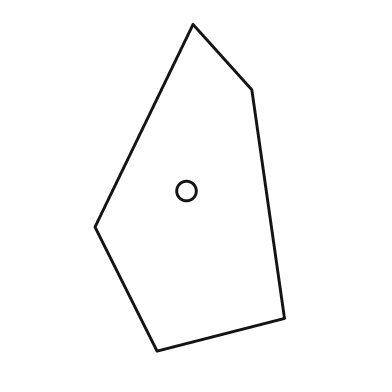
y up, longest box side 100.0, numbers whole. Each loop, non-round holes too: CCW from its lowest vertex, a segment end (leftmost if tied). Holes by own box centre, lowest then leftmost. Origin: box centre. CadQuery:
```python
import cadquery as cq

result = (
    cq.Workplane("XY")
    .moveTo(-10.0, -50.0)
    .lineTo(29.0, -40.0)
    .lineTo(19.0, 30.0)
    .lineTo(1.0, 50.0)
    .lineTo(-29.0, -12.0)
    .close()
    .moveTo(-1.0, -1.0)
    .circle(3.0)
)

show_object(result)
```